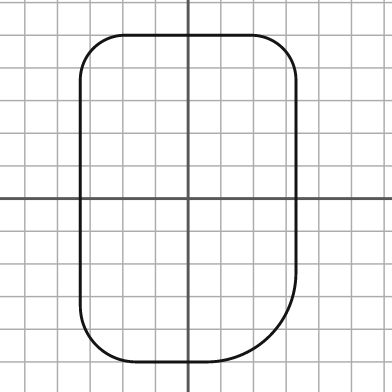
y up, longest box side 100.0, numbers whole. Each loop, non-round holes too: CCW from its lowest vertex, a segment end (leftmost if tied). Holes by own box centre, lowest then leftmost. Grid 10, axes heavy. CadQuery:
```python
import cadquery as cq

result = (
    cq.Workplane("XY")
    .moveTo(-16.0, -50.0)
    .lineTo(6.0, -50.0)
    .threePointArc((25.0, -42.0), (33.0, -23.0))
    .lineTo(33.0, 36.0)
    .threePointArc((29.0, 46.0), (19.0, 50.0))
    .lineTo(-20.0, 50.0)
    .threePointArc((-29.0, 46.0), (-33.0, 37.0))
    .lineTo(-33.0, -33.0)
    .threePointArc((-28.0, -45.0), (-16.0, -50.0))
    .close()
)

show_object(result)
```